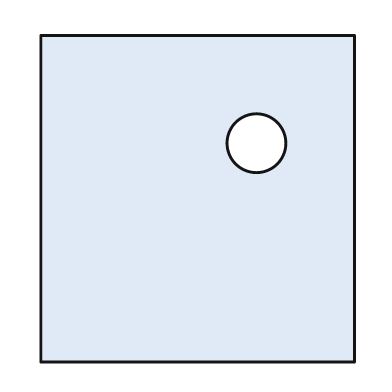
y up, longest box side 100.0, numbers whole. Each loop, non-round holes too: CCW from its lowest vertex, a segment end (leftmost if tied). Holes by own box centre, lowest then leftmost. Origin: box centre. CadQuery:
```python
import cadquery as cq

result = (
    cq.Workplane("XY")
    .moveTo(-48.0, -50.0)
    .lineTo(48.0, -50.0)
    .lineTo(48.0, 50.0)
    .lineTo(-48.0, 50.0)
    .close()
    .moveTo(18.0, 17.0)
    .circle(9.0)
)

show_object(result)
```